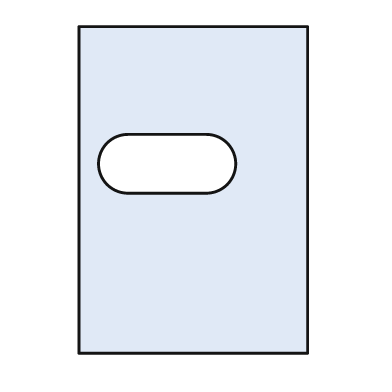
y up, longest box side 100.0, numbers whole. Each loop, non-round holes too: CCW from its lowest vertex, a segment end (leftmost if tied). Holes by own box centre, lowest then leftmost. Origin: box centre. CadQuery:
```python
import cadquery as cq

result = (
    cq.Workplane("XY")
    .moveTo(-35.0, -50.0)
    .lineTo(35.0, -50.0)
    .lineTo(35.0, 50.0)
    .lineTo(-35.0, 50.0)
    .close()
    .moveTo(-20.0, -1.0)
    .lineTo(4.0, -1.0)
    .threePointArc((13.0, 8.0), (4.0, 17.0))
    .lineTo(-20.0, 17.0)
    .threePointArc((-29.0, 8.0), (-20.0, -1.0))
    .close()
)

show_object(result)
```